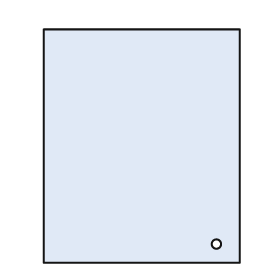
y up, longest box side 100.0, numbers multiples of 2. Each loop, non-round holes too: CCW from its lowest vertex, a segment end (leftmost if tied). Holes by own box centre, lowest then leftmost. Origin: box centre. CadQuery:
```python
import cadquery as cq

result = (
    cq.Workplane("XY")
    .moveTo(-42.0, -50.0)
    .lineTo(42.0, -50.0)
    .lineTo(42.0, 50.0)
    .lineTo(-42.0, 50.0)
    .close()
    .moveTo(32.0, -42.0)
    .circle(2.0)
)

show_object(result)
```